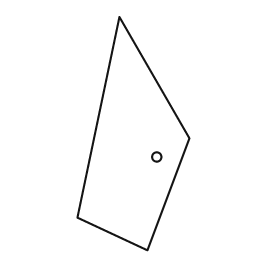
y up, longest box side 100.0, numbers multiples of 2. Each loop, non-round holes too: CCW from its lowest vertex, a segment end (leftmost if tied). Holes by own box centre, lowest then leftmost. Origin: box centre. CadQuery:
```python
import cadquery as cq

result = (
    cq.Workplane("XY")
    .moveTo(6.0, -50.0)
    .lineTo(24.0, -2.0)
    .lineTo(-6.0, 50.0)
    .lineTo(-24.0, -36.0)
    .close()
    .moveTo(10.0, -10.0)
    .circle(2.0)
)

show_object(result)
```